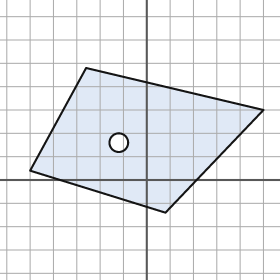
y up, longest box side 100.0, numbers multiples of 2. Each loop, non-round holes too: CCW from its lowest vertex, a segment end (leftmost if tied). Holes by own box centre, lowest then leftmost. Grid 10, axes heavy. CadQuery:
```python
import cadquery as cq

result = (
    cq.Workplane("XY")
    .moveTo(8.0, -14.0)
    .lineTo(50.0, 30.0)
    .lineTo(-26.0, 48.0)
    .lineTo(-50.0, 4.0)
    .close()
    .moveTo(-12.0, 16.0)
    .circle(4.0)
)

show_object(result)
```